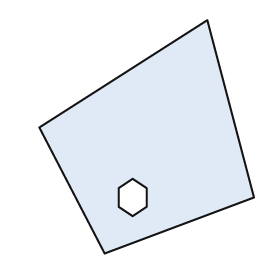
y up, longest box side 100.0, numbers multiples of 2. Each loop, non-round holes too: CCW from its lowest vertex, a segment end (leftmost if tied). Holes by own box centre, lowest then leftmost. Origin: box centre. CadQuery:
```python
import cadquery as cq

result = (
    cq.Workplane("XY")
    .moveTo(-18.0, -50.0)
    .lineTo(46.0, -26.0)
    .lineTo(26.0, 50.0)
    .lineTo(-46.0, 4.0)
    .close()
    .moveTo(-6.0, -34.0)
    .lineTo(0.0, -30.0)
    .lineTo(0.0, -22.0)
    .lineTo(-6.0, -18.0)
    .lineTo(-12.0, -22.0)
    .lineTo(-12.0, -30.0)
    .close()
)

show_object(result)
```